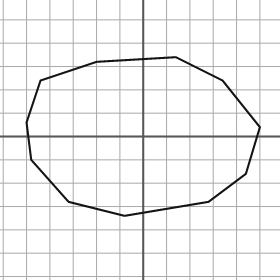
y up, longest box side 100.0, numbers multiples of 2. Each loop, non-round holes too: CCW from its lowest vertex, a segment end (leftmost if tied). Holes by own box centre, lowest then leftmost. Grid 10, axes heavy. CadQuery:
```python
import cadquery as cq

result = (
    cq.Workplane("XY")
    .moveTo(-8.0, -34.0)
    .lineTo(28.0, -28.0)
    .lineTo(44.0, -16.0)
    .lineTo(50.0, 4.0)
    .lineTo(34.0, 24.0)
    .lineTo(14.0, 34.0)
    .lineTo(-20.0, 32.0)
    .lineTo(-44.0, 24.0)
    .lineTo(-50.0, 6.0)
    .lineTo(-48.0, -10.0)
    .lineTo(-32.0, -28.0)
    .close()
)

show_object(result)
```